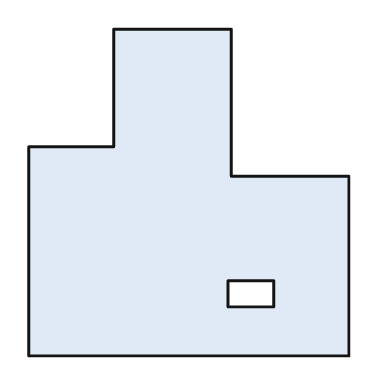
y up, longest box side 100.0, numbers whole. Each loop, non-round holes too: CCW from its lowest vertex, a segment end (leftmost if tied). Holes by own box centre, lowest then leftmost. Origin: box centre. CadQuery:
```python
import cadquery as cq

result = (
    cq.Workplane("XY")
    .moveTo(-49.0, -50.0)
    .lineTo(49.0, -50.0)
    .lineTo(49.0, 5.0)
    .lineTo(13.0, 5.0)
    .lineTo(13.0, 50.0)
    .lineTo(-23.0, 50.0)
    .lineTo(-23.0, 14.0)
    .lineTo(-49.0, 14.0)
    .close()
    .moveTo(12.0, -35.0)
    .lineTo(26.0, -35.0)
    .lineTo(26.0, -27.0)
    .lineTo(12.0, -27.0)
    .close()
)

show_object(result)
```